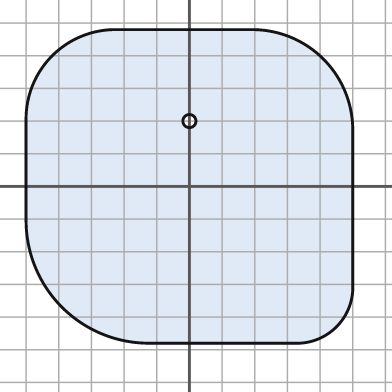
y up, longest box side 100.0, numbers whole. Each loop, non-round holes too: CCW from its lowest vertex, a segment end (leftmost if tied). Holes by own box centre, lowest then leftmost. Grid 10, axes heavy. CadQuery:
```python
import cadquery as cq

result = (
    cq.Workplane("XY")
    .moveTo(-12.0, -48.0)
    .lineTo(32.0, -48.0)
    .threePointArc((45.0, -43.0), (50.0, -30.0))
    .lineTo(50.0, 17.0)
    .threePointArc((41.0, 39.0), (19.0, 48.0))
    .lineTo(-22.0, 48.0)
    .threePointArc((-42.0, 40.0), (-50.0, 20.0))
    .lineTo(-50.0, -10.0)
    .threePointArc((-39.0, -37.0), (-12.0, -48.0))
    .close()
    .moveTo(0.0, 20.0)
    .circle(2.0)
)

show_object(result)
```